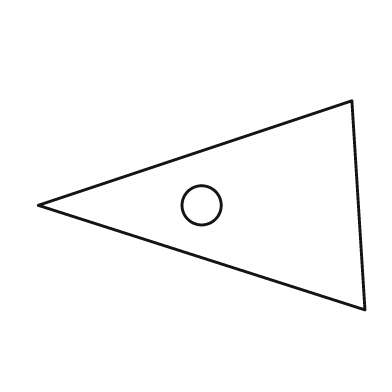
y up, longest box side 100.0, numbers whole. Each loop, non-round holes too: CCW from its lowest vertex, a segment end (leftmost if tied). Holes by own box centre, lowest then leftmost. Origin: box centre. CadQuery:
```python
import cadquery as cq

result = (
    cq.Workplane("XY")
    .moveTo(50.0, -32.0)
    .lineTo(46.0, 32.0)
    .lineTo(-50.0, 0.0)
    .close()
    .moveTo(0.0, 0.0)
    .circle(6.0)
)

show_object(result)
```